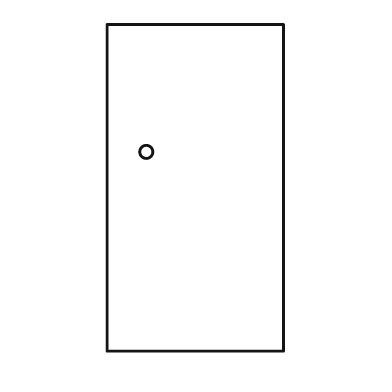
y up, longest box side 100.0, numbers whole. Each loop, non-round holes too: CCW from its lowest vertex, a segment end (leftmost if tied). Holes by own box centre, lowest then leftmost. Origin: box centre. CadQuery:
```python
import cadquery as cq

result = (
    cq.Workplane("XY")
    .moveTo(-27.0, -50.0)
    .lineTo(27.0, -50.0)
    .lineTo(27.0, 50.0)
    .lineTo(-27.0, 50.0)
    .close()
    .moveTo(-15.0, 11.0)
    .circle(2.0)
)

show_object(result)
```